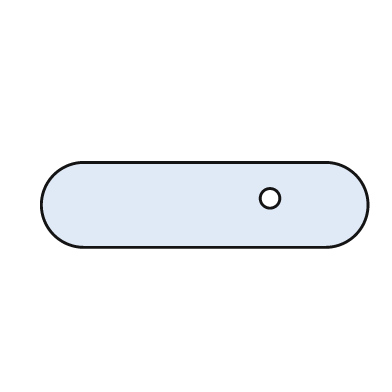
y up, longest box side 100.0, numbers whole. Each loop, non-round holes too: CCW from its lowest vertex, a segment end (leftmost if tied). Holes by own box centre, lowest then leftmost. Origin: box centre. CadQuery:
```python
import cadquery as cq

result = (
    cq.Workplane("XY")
    .moveTo(-37.0, -13.0)
    .lineTo(37.0, -13.0)
    .threePointArc((50.0, 0.0), (37.0, 13.0))
    .lineTo(-37.0, 13.0)
    .threePointArc((-50.0, 0.0), (-37.0, -13.0))
    .close()
    .moveTo(20.0, 2.0)
    .circle(3.0)
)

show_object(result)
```